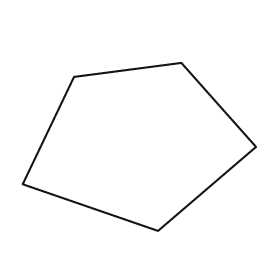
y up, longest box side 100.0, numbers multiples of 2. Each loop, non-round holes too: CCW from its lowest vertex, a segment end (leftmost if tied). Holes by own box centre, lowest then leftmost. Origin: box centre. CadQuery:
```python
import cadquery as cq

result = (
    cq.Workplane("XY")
    .moveTo(8.0, -36.0)
    .lineTo(50.0, 0.0)
    .lineTo(18.0, 36.0)
    .lineTo(-28.0, 30.0)
    .lineTo(-50.0, -16.0)
    .close()
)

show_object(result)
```